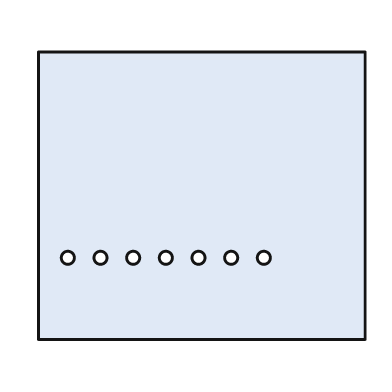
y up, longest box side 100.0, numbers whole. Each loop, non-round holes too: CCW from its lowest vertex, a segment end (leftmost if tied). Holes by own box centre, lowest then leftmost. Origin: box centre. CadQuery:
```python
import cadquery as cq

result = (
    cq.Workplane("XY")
    .moveTo(-50.0, -44.0)
    .lineTo(50.0, -44.0)
    .lineTo(50.0, 44.0)
    .lineTo(-50.0, 44.0)
    .close()
    .moveTo(-41.0, -19.0)
    .circle(2.0)
    .moveTo(-31.0, -19.0)
    .circle(2.0)
    .moveTo(-21.0, -19.0)
    .circle(2.0)
    .moveTo(-11.0, -19.0)
    .circle(2.0)
    .moveTo(-1.0, -19.0)
    .circle(2.0)
    .moveTo(9.0, -19.0)
    .circle(2.0)
    .moveTo(19.0, -19.0)
    .circle(2.0)
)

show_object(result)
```